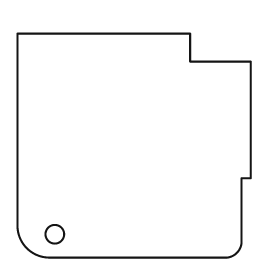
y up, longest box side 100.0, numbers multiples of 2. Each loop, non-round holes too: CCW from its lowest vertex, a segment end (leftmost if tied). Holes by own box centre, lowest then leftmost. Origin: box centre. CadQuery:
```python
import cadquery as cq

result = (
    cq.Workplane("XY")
    .moveTo(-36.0, -48.0)
    .lineTo(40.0, -48.0)
    .threePointArc((44.0, -46.0), (46.0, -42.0))
    .lineTo(46.0, -14.0)
    .lineTo(50.0, -14.0)
    .lineTo(50.0, 36.0)
    .lineTo(24.0, 36.0)
    .lineTo(24.0, 48.0)
    .lineTo(-50.0, 48.0)
    .lineTo(-50.0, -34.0)
    .threePointArc((-46.0, -44.0), (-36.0, -48.0))
    .close()
    .moveTo(-34.0, -38.0)
    .circle(4.0)
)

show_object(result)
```